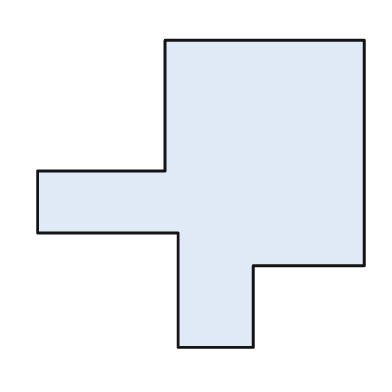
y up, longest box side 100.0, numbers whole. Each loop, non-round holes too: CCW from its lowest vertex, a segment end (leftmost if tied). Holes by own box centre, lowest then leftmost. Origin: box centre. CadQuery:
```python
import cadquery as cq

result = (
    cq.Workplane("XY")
    .moveTo(-7.0, -47.0)
    .lineTo(16.0, -47.0)
    .lineTo(16.0, -22.0)
    .lineTo(50.0, -22.0)
    .lineTo(50.0, 47.0)
    .lineTo(-11.0, 47.0)
    .lineTo(-11.0, 7.0)
    .lineTo(-50.0, 7.0)
    .lineTo(-50.0, -12.0)
    .lineTo(-7.0, -12.0)
    .close()
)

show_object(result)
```